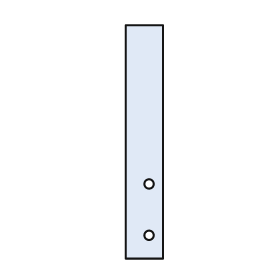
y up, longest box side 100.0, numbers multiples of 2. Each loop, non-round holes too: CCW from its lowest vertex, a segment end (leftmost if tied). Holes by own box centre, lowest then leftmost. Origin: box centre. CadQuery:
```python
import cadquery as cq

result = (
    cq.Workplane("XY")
    .moveTo(-8.0, -50.0)
    .lineTo(8.0, -50.0)
    .lineTo(8.0, 50.0)
    .lineTo(-8.0, 50.0)
    .close()
    .moveTo(2.0, -40.0)
    .circle(2.0)
    .moveTo(2.0, -18.0)
    .circle(2.0)
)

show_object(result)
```